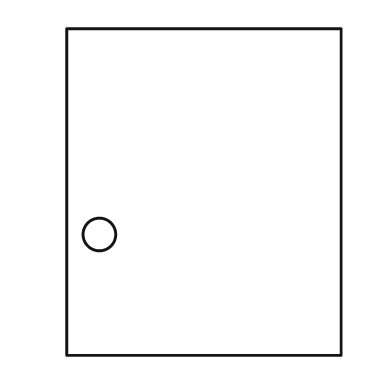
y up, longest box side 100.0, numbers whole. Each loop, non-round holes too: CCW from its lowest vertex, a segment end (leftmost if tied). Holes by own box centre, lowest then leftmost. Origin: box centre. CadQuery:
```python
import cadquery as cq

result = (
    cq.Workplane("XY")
    .moveTo(-42.0, -50.0)
    .lineTo(42.0, -50.0)
    .lineTo(42.0, 50.0)
    .lineTo(-42.0, 50.0)
    .close()
    .moveTo(-32.0, -13.0)
    .circle(5.0)
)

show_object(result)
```